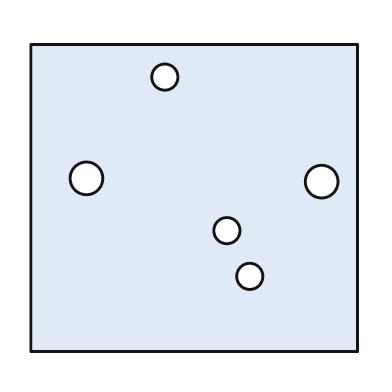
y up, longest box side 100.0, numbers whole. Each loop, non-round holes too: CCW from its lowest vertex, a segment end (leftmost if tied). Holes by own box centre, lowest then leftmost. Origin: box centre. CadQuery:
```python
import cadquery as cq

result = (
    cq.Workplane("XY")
    .moveTo(-50.0, -47.0)
    .lineTo(50.0, -47.0)
    .lineTo(50.0, 47.0)
    .lineTo(-50.0, 47.0)
    .close()
    .moveTo(17.0, -24.0)
    .circle(4.0)
    .moveTo(10.0, -10.0)
    .circle(4.0)
    .moveTo(39.0, 5.0)
    .circle(5.0)
    .moveTo(-33.0, 6.0)
    .circle(5.0)
    .moveTo(-9.0, 37.0)
    .circle(4.0)
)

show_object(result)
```